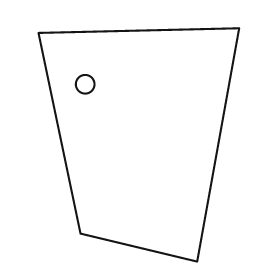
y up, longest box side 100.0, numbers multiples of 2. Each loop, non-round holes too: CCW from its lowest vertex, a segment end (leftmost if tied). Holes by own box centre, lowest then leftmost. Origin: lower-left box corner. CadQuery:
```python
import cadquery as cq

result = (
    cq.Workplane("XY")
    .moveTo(68.0, 0.0)
    .lineTo(86.0, 100.0)
    .lineTo(0.0, 98.0)
    .lineTo(18.0, 12.0)
    .close()
    .moveTo(20.0, 76.0)
    .circle(4.0)
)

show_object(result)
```